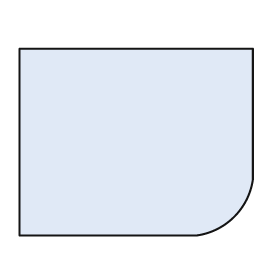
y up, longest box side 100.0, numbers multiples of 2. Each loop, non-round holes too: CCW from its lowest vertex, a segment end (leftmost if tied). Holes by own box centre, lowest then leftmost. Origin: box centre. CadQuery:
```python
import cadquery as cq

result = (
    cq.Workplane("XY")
    .moveTo(-50.0, -40.0)
    .lineTo(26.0, -40.0)
    .threePointArc((42.0, -32.0), (50.0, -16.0))
    .lineTo(50.0, 40.0)
    .lineTo(-50.0, 40.0)
    .close()
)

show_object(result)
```